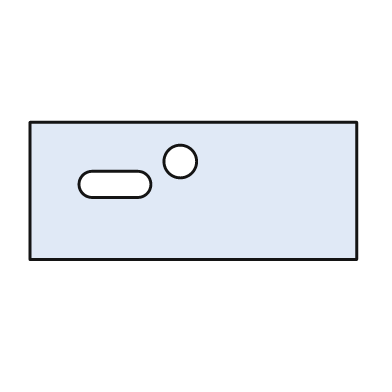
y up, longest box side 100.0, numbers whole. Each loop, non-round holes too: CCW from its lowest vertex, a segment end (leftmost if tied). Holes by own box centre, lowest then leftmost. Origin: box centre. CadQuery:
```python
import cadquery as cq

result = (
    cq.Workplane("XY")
    .moveTo(-50.0, -21.0)
    .lineTo(50.0, -21.0)
    .lineTo(50.0, 21.0)
    .lineTo(-50.0, 21.0)
    .close()
    .moveTo(-31.0, -2.0)
    .lineTo(-17.0, -2.0)
    .threePointArc((-13.0, 2.0), (-17.0, 6.0))
    .lineTo(-31.0, 6.0)
    .threePointArc((-35.0, 2.0), (-31.0, -2.0))
    .close()
    .moveTo(-4.0, 9.0)
    .circle(5.0)
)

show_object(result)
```